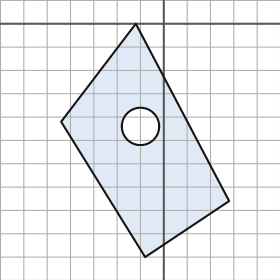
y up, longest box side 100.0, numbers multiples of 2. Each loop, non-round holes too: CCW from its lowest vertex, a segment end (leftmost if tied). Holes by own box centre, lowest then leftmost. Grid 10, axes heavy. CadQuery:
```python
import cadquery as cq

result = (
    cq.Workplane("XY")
    .moveTo(-8.0, -100.0)
    .lineTo(28.0, -76.0)
    .lineTo(-12.0, 0.0)
    .lineTo(-44.0, -42.0)
    .close()
    .moveTo(-10.0, -44.0)
    .circle(8.0)
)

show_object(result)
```